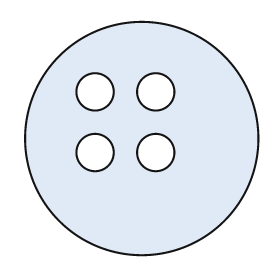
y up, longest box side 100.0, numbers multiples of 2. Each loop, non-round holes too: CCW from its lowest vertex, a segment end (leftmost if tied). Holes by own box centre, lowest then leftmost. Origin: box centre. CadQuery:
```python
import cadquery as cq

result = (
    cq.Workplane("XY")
    .moveTo(0.0, 0.0)
    .circle(50.0)
    .moveTo(-20.0, -6.0)
    .circle(8.0)
    .moveTo(6.0, -6.0)
    .circle(8.0)
    .moveTo(-20.0, 20.0)
    .circle(8.0)
    .moveTo(6.0, 20.0)
    .circle(8.0)
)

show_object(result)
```